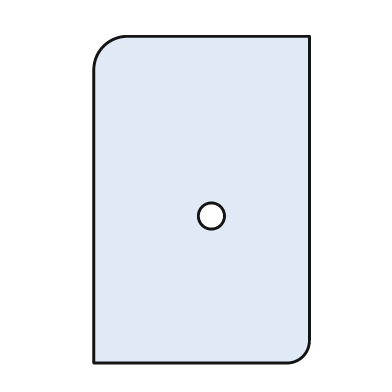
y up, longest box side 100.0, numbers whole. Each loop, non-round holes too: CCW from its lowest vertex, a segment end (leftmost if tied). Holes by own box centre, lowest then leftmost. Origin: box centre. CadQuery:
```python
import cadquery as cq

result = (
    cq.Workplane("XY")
    .moveTo(-33.0, -50.0)
    .lineTo(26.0, -50.0)
    .threePointArc((31.0, -48.0), (33.0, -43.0))
    .lineTo(33.0, 50.0)
    .lineTo(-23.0, 50.0)
    .threePointArc((-30.0, 47.0), (-33.0, 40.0))
    .close()
    .moveTo(3.0, -5.0)
    .circle(4.0)
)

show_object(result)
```